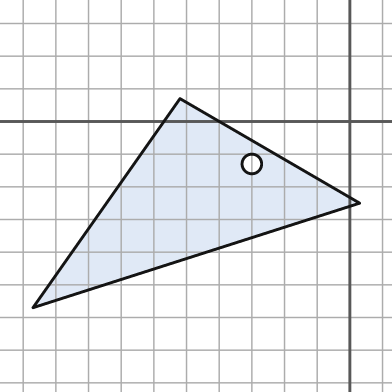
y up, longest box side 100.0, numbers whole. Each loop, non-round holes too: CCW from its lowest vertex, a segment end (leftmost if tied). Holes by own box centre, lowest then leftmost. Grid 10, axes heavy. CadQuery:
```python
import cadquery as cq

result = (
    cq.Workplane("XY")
    .moveTo(-97.0, -57.0)
    .lineTo(3.0, -25.0)
    .lineTo(-52.0, 7.0)
    .close()
    .moveTo(-30.0, -13.0)
    .circle(3.0)
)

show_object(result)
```